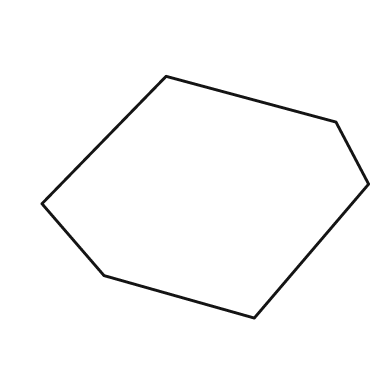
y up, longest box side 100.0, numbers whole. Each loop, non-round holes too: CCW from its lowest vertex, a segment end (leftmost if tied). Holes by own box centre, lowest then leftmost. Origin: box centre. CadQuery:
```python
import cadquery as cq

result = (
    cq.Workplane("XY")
    .moveTo(15.0, -37.0)
    .lineTo(50.0, 4.0)
    .lineTo(40.0, 23.0)
    .lineTo(-12.0, 37.0)
    .lineTo(-50.0, -2.0)
    .lineTo(-31.0, -24.0)
    .close()
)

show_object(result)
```